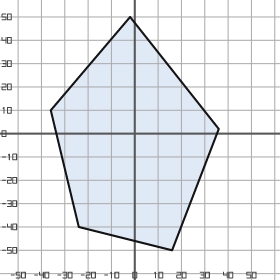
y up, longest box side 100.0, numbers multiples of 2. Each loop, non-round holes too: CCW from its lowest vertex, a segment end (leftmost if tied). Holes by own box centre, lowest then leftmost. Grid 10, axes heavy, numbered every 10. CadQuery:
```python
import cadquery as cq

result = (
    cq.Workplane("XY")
    .moveTo(16.0, -50.0)
    .lineTo(36.0, 2.0)
    .lineTo(-2.0, 50.0)
    .lineTo(-36.0, 10.0)
    .lineTo(-24.0, -40.0)
    .close()
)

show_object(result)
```